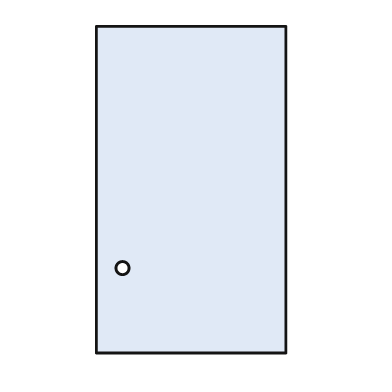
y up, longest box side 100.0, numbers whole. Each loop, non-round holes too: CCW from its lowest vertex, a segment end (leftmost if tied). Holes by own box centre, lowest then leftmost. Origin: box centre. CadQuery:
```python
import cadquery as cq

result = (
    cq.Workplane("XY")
    .moveTo(-29.0, -50.0)
    .lineTo(29.0, -50.0)
    .lineTo(29.0, 50.0)
    .lineTo(-29.0, 50.0)
    .close()
    .moveTo(-21.0, -24.0)
    .circle(2.0)
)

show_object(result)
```